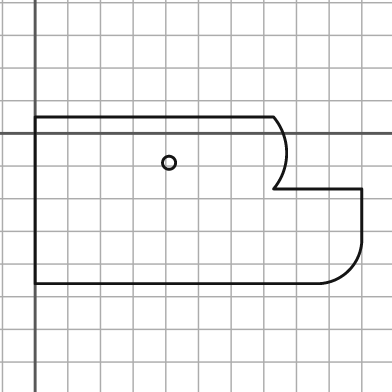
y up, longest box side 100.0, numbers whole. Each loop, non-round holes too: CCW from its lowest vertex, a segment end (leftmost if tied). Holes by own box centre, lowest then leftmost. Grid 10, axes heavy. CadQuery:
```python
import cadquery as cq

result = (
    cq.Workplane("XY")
    .moveTo(0.0, -46.0)
    .lineTo(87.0, -46.0)
    .threePointArc((96.0, -42.0), (100.0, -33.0))
    .lineTo(100.0, -17.0)
    .lineTo(73.0, -17.0)
    .threePointArc((77.0, -6.0), (73.0, 5.0))
    .lineTo(0.0, 5.0)
    .close()
    .moveTo(41.0, -9.0)
    .circle(2.0)
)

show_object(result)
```